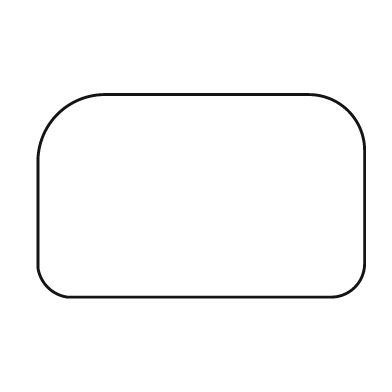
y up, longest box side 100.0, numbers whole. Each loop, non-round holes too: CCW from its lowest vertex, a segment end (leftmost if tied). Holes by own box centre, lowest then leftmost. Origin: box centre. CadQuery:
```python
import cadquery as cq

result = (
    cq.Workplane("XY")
    .moveTo(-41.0, -31.0)
    .lineTo(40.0, -31.0)
    .threePointArc((47.0, -28.0), (50.0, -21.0))
    .lineTo(50.0, 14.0)
    .threePointArc((45.0, 26.0), (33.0, 31.0))
    .lineTo(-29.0, 31.0)
    .threePointArc((-44.0, 25.0), (-50.0, 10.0))
    .lineTo(-50.0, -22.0)
    .threePointArc((-47.0, -28.0), (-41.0, -31.0))
    .close()
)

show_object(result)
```